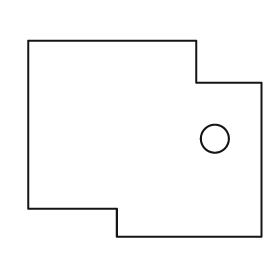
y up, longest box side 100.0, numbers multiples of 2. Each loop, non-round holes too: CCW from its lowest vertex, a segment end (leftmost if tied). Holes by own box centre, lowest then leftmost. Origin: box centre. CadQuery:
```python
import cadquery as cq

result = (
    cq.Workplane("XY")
    .moveTo(-12.0, -42.0)
    .lineTo(50.0, -42.0)
    .lineTo(50.0, 24.0)
    .lineTo(22.0, 24.0)
    .lineTo(22.0, 42.0)
    .lineTo(-50.0, 42.0)
    .lineTo(-50.0, -30.0)
    .lineTo(-12.0, -30.0)
    .close()
    .moveTo(30.0, 0.0)
    .circle(6.0)
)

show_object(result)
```